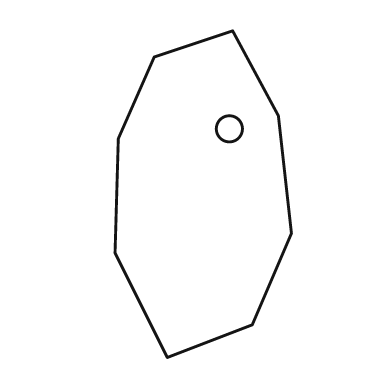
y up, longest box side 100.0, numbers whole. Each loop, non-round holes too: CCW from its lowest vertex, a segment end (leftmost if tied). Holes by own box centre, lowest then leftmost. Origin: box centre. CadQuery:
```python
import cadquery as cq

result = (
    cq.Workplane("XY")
    .moveTo(-11.0, -50.0)
    .lineTo(15.0, -40.0)
    .lineTo(27.0, -12.0)
    .lineTo(23.0, 24.0)
    .lineTo(9.0, 50.0)
    .lineTo(-15.0, 42.0)
    .lineTo(-26.0, 17.0)
    .lineTo(-27.0, -18.0)
    .close()
    .moveTo(8.0, 20.0)
    .circle(4.0)
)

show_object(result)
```